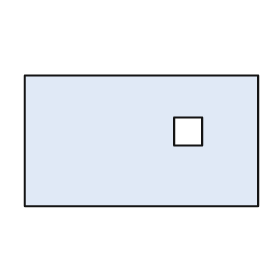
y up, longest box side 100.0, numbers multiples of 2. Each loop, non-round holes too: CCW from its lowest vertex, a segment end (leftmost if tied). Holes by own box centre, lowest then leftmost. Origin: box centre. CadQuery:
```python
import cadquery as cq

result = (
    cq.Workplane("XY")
    .moveTo(-50.0, -28.0)
    .lineTo(50.0, -28.0)
    .lineTo(50.0, 28.0)
    .lineTo(-50.0, 28.0)
    .close()
    .moveTo(14.0, -2.0)
    .lineTo(26.0, -2.0)
    .lineTo(26.0, 10.0)
    .lineTo(14.0, 10.0)
    .close()
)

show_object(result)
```